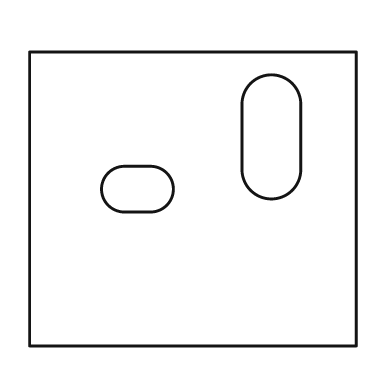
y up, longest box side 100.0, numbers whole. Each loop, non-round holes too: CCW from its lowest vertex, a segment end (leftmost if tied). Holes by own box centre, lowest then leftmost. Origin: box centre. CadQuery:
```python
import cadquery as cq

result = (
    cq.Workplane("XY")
    .moveTo(-50.0, -45.0)
    .lineTo(50.0, -45.0)
    .lineTo(50.0, 45.0)
    .lineTo(-50.0, 45.0)
    .close()
    .moveTo(-21.0, -4.0)
    .lineTo(-13.0, -4.0)
    .threePointArc((-6.0, 3.0), (-13.0, 10.0))
    .lineTo(-21.0, 10.0)
    .threePointArc((-28.0, 3.0), (-21.0, -4.0))
    .close()
    .moveTo(15.0, 9.0)
    .threePointArc((24.0, 0.0), (33.0, 9.0))
    .lineTo(33.0, 29.0)
    .threePointArc((24.0, 38.0), (15.0, 29.0))
    .close()
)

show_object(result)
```